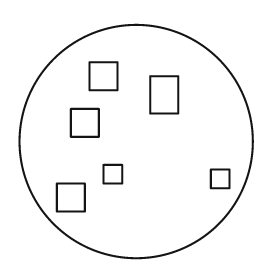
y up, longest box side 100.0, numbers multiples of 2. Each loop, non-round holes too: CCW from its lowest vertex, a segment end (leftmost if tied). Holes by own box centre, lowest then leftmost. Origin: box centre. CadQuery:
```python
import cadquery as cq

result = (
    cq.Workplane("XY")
    .moveTo(0.0, 0.0)
    .circle(50.0)
    .moveTo(-34.0, -30.0)
    .lineTo(-22.0, -30.0)
    .lineTo(-22.0, -18.0)
    .lineTo(-34.0, -18.0)
    .close()
    .moveTo(32.0, -20.0)
    .lineTo(40.0, -20.0)
    .lineTo(40.0, -12.0)
    .lineTo(32.0, -12.0)
    .close()
    .moveTo(-14.0, -18.0)
    .lineTo(-6.0, -18.0)
    .lineTo(-6.0, -10.0)
    .lineTo(-14.0, -10.0)
    .close()
    .moveTo(-28.0, 2.0)
    .lineTo(-16.0, 2.0)
    .lineTo(-16.0, 14.0)
    .lineTo(-28.0, 14.0)
    .close()
    .moveTo(6.0, 12.0)
    .lineTo(18.0, 12.0)
    .lineTo(18.0, 28.0)
    .lineTo(6.0, 28.0)
    .close()
    .moveTo(-20.0, 22.0)
    .lineTo(-8.0, 22.0)
    .lineTo(-8.0, 34.0)
    .lineTo(-20.0, 34.0)
    .close()
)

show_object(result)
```